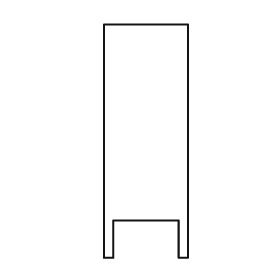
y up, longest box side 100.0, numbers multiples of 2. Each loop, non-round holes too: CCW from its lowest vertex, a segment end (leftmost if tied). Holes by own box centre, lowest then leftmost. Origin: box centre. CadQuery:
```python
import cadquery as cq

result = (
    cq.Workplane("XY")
    .moveTo(-18.0, -50.0)
    .lineTo(-14.0, -50.0)
    .lineTo(-14.0, -34.0)
    .lineTo(14.0, -34.0)
    .lineTo(14.0, -50.0)
    .lineTo(18.0, -50.0)
    .lineTo(18.0, 50.0)
    .lineTo(-18.0, 50.0)
    .close()
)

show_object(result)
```